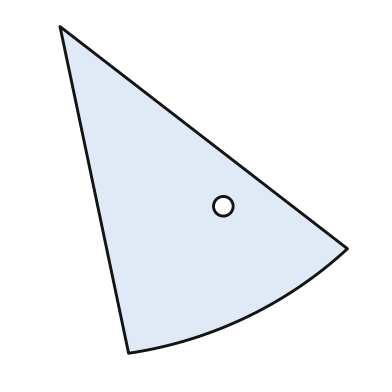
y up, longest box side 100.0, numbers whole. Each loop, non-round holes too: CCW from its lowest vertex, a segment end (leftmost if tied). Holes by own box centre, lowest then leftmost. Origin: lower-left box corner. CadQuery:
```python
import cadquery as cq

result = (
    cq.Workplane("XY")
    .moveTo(21.0, 0.0)
    .threePointArc((57.0, 11.0), (88.0, 32.0))
    .lineTo(0.0, 100.0)
    .close()
    .moveTo(50.0, 45.0)
    .circle(3.0)
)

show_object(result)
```